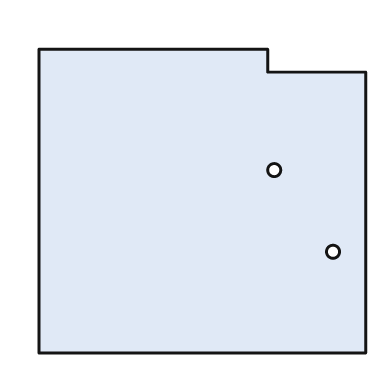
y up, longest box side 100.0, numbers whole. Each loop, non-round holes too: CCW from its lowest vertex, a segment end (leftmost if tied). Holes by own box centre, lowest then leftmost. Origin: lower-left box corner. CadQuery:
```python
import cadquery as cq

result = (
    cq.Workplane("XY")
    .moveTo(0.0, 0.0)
    .lineTo(100.0, 0.0)
    .lineTo(100.0, 86.0)
    .lineTo(70.0, 86.0)
    .lineTo(70.0, 93.0)
    .lineTo(0.0, 93.0)
    .close()
    .moveTo(90.0, 31.0)
    .circle(2.0)
    .moveTo(72.0, 56.0)
    .circle(2.0)
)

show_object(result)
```